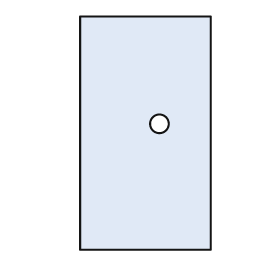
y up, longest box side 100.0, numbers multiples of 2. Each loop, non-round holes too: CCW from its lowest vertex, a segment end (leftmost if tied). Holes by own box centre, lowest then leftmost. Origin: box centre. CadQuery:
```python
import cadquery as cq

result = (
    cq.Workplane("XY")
    .moveTo(-28.0, -50.0)
    .lineTo(28.0, -50.0)
    .lineTo(28.0, 50.0)
    .lineTo(-28.0, 50.0)
    .close()
    .moveTo(6.0, 4.0)
    .circle(4.0)
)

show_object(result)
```